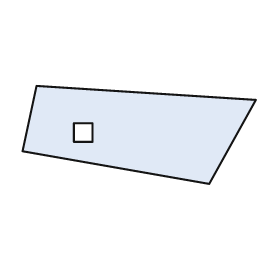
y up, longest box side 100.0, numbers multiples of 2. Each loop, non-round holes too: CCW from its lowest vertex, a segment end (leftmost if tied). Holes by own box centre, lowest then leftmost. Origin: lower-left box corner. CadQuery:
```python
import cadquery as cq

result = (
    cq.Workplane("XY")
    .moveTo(80.0, 0.0)
    .lineTo(100.0, 36.0)
    .lineTo(6.0, 42.0)
    .lineTo(0.0, 14.0)
    .close()
    .moveTo(22.0, 18.0)
    .lineTo(30.0, 18.0)
    .lineTo(30.0, 26.0)
    .lineTo(22.0, 26.0)
    .close()
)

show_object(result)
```